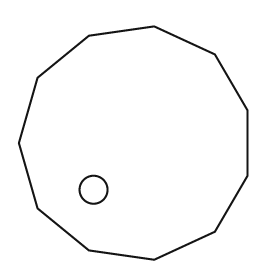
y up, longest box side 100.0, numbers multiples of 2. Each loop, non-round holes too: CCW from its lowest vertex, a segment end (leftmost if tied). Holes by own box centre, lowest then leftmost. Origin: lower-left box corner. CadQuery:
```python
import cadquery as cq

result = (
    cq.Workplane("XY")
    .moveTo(58.0, 0.0)
    .lineTo(84.0, 12.0)
    .lineTo(98.0, 36.0)
    .lineTo(98.0, 64.0)
    .lineTo(84.0, 88.0)
    .lineTo(58.0, 100.0)
    .lineTo(30.0, 96.0)
    .lineTo(8.0, 78.0)
    .lineTo(0.0, 50.0)
    .lineTo(8.0, 22.0)
    .lineTo(30.0, 4.0)
    .close()
    .moveTo(32.0, 30.0)
    .circle(6.0)
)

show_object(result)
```